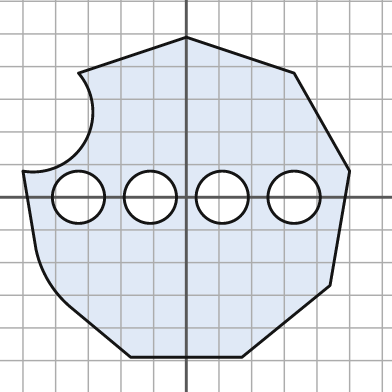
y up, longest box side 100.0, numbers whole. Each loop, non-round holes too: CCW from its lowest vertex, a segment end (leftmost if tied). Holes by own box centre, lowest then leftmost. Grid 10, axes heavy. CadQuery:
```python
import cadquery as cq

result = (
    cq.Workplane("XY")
    .moveTo(-17.0, -49.0)
    .lineTo(17.0, -49.0)
    .lineTo(44.0, -27.0)
    .lineTo(50.0, 8.0)
    .lineTo(33.0, 38.0)
    .lineTo(0.0, 49.0)
    .lineTo(-33.0, 38.0)
    .threePointArc((-31.0, 17.0), (-50.0, 8.0))
    .lineTo(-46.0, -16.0)
    .threePointArc((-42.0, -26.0), (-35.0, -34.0))
    .close()
    .moveTo(-33.0, 0.0)
    .circle(8.0)
    .moveTo(-11.0, 0.0)
    .circle(8.0)
    .moveTo(11.0, 0.0)
    .circle(8.0)
    .moveTo(33.0, 0.0)
    .circle(8.0)
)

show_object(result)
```